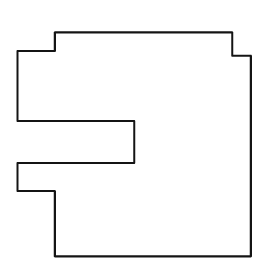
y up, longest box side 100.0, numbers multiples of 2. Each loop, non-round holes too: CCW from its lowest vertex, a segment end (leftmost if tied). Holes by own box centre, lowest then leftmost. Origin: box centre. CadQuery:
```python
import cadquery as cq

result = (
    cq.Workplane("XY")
    .moveTo(-34.0, -48.0)
    .lineTo(50.0, -48.0)
    .lineTo(50.0, 38.0)
    .lineTo(42.0, 38.0)
    .lineTo(42.0, 48.0)
    .lineTo(-34.0, 48.0)
    .lineTo(-34.0, 40.0)
    .lineTo(-50.0, 40.0)
    .lineTo(-50.0, 10.0)
    .lineTo(0.0, 10.0)
    .lineTo(0.0, -8.0)
    .lineTo(-50.0, -8.0)
    .lineTo(-50.0, -20.0)
    .lineTo(-34.0, -20.0)
    .close()
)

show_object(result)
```